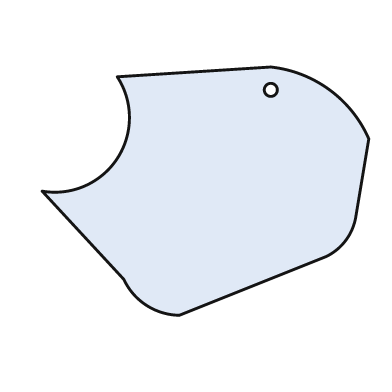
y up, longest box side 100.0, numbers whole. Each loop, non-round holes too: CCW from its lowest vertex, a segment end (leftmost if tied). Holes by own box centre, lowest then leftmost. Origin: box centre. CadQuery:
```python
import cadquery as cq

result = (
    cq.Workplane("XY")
    .moveTo(-8.0, -38.0)
    .lineTo(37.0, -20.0)
    .threePointArc((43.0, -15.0), (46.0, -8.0))
    .lineTo(50.0, 16.0)
    .threePointArc((38.0, 31.0), (20.0, 38.0))
    .lineTo(-27.0, 35.0)
    .threePointArc((-27.0, 10.0), (-50.0, 0.0))
    .lineTo(-25.0, -27.0)
    .threePointArc((-18.0, -35.0), (-8.0, -38.0))
    .close()
    .moveTo(20.0, 31.0)
    .circle(2.0)
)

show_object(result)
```